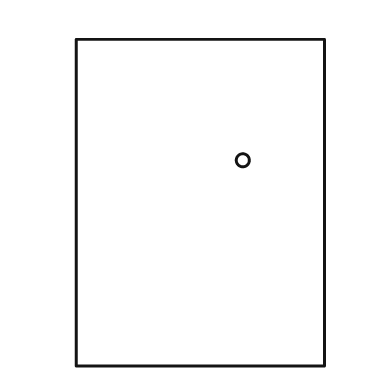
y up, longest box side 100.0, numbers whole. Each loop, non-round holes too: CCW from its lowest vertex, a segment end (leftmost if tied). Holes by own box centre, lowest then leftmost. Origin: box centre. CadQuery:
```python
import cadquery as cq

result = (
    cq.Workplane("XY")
    .moveTo(-38.0, -50.0)
    .lineTo(38.0, -50.0)
    .lineTo(38.0, 50.0)
    .lineTo(-38.0, 50.0)
    .close()
    .moveTo(13.0, 13.0)
    .circle(2.0)
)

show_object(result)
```